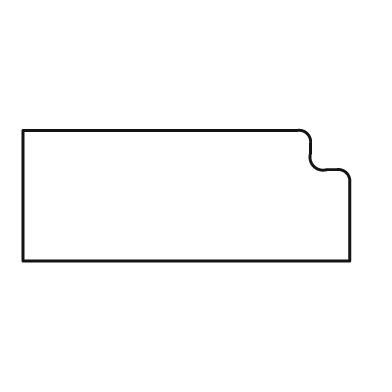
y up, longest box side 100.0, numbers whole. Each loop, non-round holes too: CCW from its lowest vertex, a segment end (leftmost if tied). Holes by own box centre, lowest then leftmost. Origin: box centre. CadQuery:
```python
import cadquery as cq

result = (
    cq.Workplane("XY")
    .moveTo(-50.0, -20.0)
    .lineTo(50.0, -20.0)
    .lineTo(50.0, 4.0)
    .threePointArc((49.0, 7.0), (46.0, 8.0))
    .lineTo(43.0, 8.0)
    .threePointArc((39.0, 9.0), (38.0, 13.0))
    .lineTo(38.0, 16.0)
    .threePointArc((37.0, 19.0), (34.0, 20.0))
    .lineTo(-50.0, 20.0)
    .close()
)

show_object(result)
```